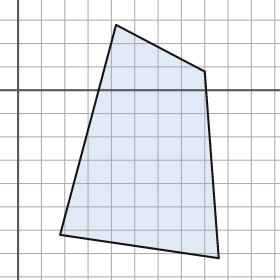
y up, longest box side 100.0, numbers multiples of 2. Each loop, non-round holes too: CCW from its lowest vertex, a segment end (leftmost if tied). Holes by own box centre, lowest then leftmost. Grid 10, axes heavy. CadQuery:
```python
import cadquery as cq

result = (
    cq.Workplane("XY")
    .moveTo(86.0, -72.0)
    .lineTo(80.0, 8.0)
    .lineTo(42.0, 28.0)
    .lineTo(18.0, -62.0)
    .close()
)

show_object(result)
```